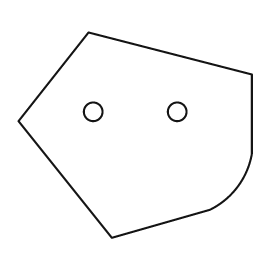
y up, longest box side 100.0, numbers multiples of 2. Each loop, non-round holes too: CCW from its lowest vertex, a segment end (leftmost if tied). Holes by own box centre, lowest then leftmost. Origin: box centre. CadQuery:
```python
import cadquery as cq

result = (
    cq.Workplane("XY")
    .moveTo(-10.0, -44.0)
    .lineTo(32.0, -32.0)
    .threePointArc((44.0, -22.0), (50.0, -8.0))
    .lineTo(50.0, 26.0)
    .lineTo(-20.0, 44.0)
    .lineTo(-50.0, 6.0)
    .close()
    .moveTo(-18.0, 10.0)
    .circle(4.0)
    .moveTo(18.0, 10.0)
    .circle(4.0)
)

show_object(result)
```